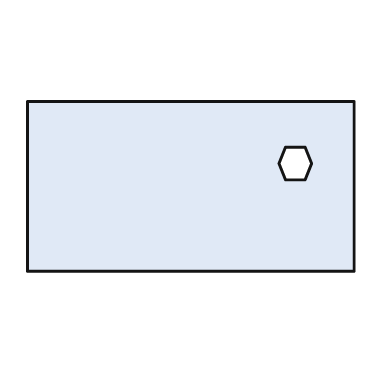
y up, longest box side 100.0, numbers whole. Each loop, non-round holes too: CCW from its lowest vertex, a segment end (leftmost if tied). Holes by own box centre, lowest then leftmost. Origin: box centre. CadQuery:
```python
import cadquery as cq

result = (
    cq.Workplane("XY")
    .moveTo(-50.0, -26.0)
    .lineTo(50.0, -26.0)
    .lineTo(50.0, 26.0)
    .lineTo(-50.0, 26.0)
    .close()
    .moveTo(29.0, 2.0)
    .lineTo(35.0, 2.0)
    .lineTo(37.0, 7.0)
    .lineTo(35.0, 12.0)
    .lineTo(29.0, 12.0)
    .lineTo(27.0, 7.0)
    .close()
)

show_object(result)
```